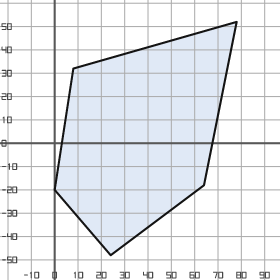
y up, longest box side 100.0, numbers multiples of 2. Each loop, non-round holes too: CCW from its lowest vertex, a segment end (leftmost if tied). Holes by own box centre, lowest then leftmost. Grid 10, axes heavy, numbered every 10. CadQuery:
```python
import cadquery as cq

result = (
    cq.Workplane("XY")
    .moveTo(24.0, -48.0)
    .lineTo(64.0, -18.0)
    .lineTo(78.0, 52.0)
    .lineTo(8.0, 32.0)
    .lineTo(0.0, -20.0)
    .close()
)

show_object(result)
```